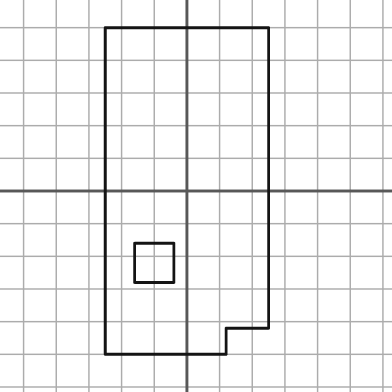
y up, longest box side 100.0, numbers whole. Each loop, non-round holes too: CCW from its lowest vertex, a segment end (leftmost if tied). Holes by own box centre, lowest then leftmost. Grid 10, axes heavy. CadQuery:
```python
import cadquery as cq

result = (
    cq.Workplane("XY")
    .moveTo(-25.0, -50.0)
    .lineTo(12.0, -50.0)
    .lineTo(12.0, -42.0)
    .lineTo(25.0, -42.0)
    .lineTo(25.0, 50.0)
    .lineTo(-25.0, 50.0)
    .close()
    .moveTo(-16.0, -28.0)
    .lineTo(-4.0, -28.0)
    .lineTo(-4.0, -16.0)
    .lineTo(-16.0, -16.0)
    .close()
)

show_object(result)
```